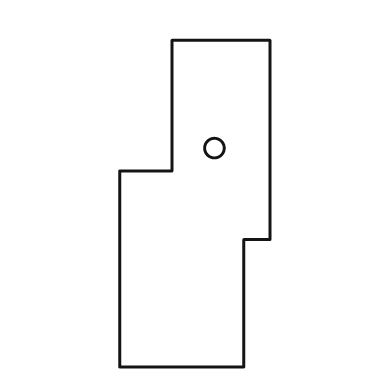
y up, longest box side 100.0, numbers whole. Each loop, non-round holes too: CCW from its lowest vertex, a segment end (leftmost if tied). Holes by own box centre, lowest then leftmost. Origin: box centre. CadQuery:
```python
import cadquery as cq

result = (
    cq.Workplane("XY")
    .moveTo(-23.0, -50.0)
    .lineTo(15.0, -50.0)
    .lineTo(15.0, -11.0)
    .lineTo(23.0, -11.0)
    .lineTo(23.0, 50.0)
    .lineTo(-7.0, 50.0)
    .lineTo(-7.0, 10.0)
    .lineTo(-23.0, 10.0)
    .close()
    .moveTo(6.0, 17.0)
    .circle(3.0)
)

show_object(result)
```